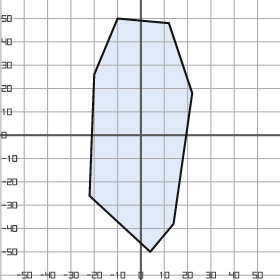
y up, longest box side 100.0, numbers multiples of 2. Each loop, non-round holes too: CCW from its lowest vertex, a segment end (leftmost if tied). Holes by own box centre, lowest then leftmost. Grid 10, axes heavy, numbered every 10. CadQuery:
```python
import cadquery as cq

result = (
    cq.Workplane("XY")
    .moveTo(4.0, -50.0)
    .lineTo(14.0, -38.0)
    .lineTo(22.0, 18.0)
    .lineTo(12.0, 48.0)
    .lineTo(-10.0, 50.0)
    .lineTo(-20.0, 26.0)
    .lineTo(-22.0, -26.0)
    .close()
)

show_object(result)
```